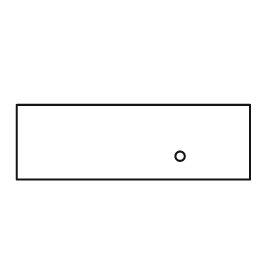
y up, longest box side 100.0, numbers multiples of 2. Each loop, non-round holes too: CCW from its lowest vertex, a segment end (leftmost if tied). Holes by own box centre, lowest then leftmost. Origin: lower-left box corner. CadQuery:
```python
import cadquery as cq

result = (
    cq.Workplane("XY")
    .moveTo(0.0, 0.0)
    .lineTo(100.0, 0.0)
    .lineTo(100.0, 32.0)
    .lineTo(0.0, 32.0)
    .close()
    .moveTo(70.0, 10.0)
    .circle(2.0)
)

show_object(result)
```